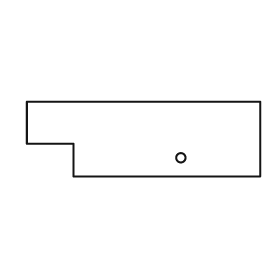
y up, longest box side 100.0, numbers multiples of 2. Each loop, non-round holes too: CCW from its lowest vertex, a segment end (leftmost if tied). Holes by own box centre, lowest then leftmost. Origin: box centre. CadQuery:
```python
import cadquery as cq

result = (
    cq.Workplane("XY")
    .moveTo(-30.0, -16.0)
    .lineTo(50.0, -16.0)
    .lineTo(50.0, 16.0)
    .lineTo(-50.0, 16.0)
    .lineTo(-50.0, -2.0)
    .lineTo(-30.0, -2.0)
    .close()
    .moveTo(16.0, -8.0)
    .circle(2.0)
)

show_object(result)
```